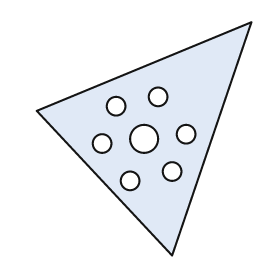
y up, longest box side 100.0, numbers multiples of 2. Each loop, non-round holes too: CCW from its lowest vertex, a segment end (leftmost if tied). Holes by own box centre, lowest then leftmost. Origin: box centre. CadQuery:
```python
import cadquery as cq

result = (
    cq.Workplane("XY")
    .moveTo(12.0, -50.0)
    .lineTo(46.0, 50.0)
    .lineTo(-46.0, 12.0)
    .close()
    .moveTo(-6.0, -18.0)
    .circle(4.0)
    .moveTo(12.0, -14.0)
    .circle(4.0)
    .moveTo(-18.0, -2.0)
    .circle(4.0)
    .moveTo(0.0, 0.0)
    .circle(6.0)
    .moveTo(18.0, 2.0)
    .circle(4.0)
    .moveTo(-12.0, 14.0)
    .circle(4.0)
    .moveTo(6.0, 18.0)
    .circle(4.0)
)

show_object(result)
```